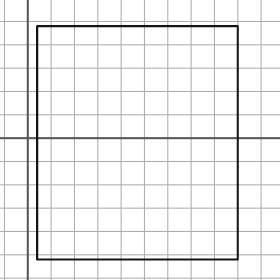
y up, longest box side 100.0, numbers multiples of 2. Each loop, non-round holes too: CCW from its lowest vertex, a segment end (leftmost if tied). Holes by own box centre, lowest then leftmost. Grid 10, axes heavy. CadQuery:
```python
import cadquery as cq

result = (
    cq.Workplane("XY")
    .moveTo(4.0, -52.0)
    .lineTo(90.0, -52.0)
    .lineTo(90.0, 48.0)
    .lineTo(4.0, 48.0)
    .close()
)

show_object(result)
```